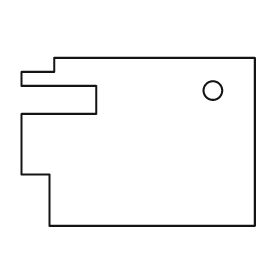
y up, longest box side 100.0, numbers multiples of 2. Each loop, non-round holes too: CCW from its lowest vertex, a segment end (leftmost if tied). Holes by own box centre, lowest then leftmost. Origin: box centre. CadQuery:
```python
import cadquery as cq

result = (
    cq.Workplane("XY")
    .moveTo(-38.0, -36.0)
    .lineTo(50.0, -36.0)
    .lineTo(50.0, 36.0)
    .lineTo(-36.0, 36.0)
    .lineTo(-36.0, 30.0)
    .lineTo(-50.0, 30.0)
    .lineTo(-50.0, 24.0)
    .lineTo(-18.0, 24.0)
    .lineTo(-18.0, 12.0)
    .lineTo(-50.0, 12.0)
    .lineTo(-50.0, -14.0)
    .lineTo(-38.0, -14.0)
    .close()
    .moveTo(32.0, 22.0)
    .circle(4.0)
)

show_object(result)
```